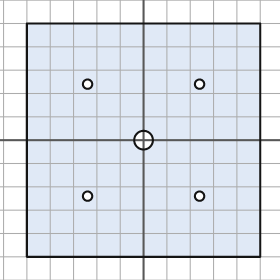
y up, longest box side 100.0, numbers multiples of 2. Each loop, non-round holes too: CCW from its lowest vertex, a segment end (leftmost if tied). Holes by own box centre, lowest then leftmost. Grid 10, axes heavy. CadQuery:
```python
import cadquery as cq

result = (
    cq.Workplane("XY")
    .moveTo(-50.0, -50.0)
    .lineTo(50.0, -50.0)
    .lineTo(50.0, 50.0)
    .lineTo(-50.0, 50.0)
    .close()
    .moveTo(-24.0, -24.0)
    .circle(2.0)
    .moveTo(24.0, -24.0)
    .circle(2.0)
    .moveTo(0.0, 0.0)
    .circle(4.0)
    .moveTo(-24.0, 24.0)
    .circle(2.0)
    .moveTo(24.0, 24.0)
    .circle(2.0)
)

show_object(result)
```